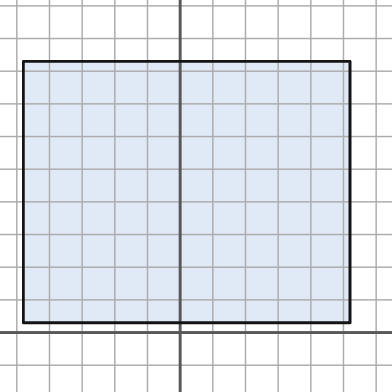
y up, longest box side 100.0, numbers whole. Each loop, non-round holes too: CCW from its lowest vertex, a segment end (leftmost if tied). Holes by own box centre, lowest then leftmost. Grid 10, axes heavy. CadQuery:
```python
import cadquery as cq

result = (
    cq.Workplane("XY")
    .moveTo(-48.0, 3.0)
    .lineTo(52.0, 3.0)
    .lineTo(52.0, 83.0)
    .lineTo(-48.0, 83.0)
    .close()
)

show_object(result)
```